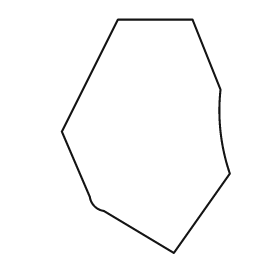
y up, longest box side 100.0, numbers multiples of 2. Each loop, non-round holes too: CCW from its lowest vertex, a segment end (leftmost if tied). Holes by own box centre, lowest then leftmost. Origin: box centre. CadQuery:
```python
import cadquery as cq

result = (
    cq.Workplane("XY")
    .moveTo(12.0, -50.0)
    .lineTo(36.0, -16.0)
    .threePointArc((32.0, 2.0), (32.0, 20.0))
    .lineTo(20.0, 50.0)
    .lineTo(-12.0, 50.0)
    .lineTo(-36.0, 2.0)
    .lineTo(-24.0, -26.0)
    .threePointArc((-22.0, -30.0), (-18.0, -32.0))
    .close()
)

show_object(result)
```